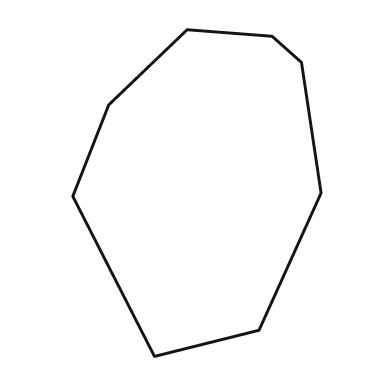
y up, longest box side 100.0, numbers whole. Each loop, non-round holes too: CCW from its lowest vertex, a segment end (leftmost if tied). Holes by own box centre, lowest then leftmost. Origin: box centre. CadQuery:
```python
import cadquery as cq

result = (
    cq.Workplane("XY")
    .moveTo(-13.0, -50.0)
    .lineTo(19.0, -42.0)
    .lineTo(38.0, 0.0)
    .lineTo(32.0, 40.0)
    .lineTo(23.0, 48.0)
    .lineTo(-3.0, 50.0)
    .lineTo(-27.0, 27.0)
    .lineTo(-38.0, -1.0)
    .close()
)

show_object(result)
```